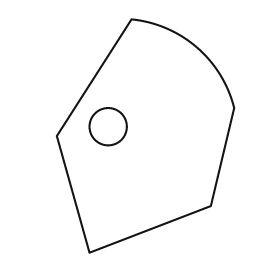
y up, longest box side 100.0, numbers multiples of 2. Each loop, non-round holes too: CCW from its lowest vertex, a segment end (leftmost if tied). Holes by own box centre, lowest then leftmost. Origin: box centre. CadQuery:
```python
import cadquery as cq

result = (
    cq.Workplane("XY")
    .moveTo(-24.0, -50.0)
    .lineTo(28.0, -30.0)
    .lineTo(38.0, 12.0)
    .threePointArc((22.0, 38.0), (-6.0, 50.0))
    .lineTo(-38.0, 0.0)
    .close()
    .moveTo(-16.0, 4.0)
    .circle(8.0)
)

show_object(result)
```